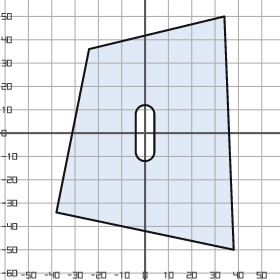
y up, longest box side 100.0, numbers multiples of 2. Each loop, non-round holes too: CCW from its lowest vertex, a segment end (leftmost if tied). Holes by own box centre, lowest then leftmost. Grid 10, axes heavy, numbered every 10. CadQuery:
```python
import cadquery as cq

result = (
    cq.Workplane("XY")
    .moveTo(38.0, -50.0)
    .lineTo(34.0, 50.0)
    .lineTo(-24.0, 36.0)
    .lineTo(-38.0, -34.0)
    .close()
    .moveTo(-4.0, -8.0)
    .threePointArc((0.0, -12.0), (4.0, -8.0))
    .lineTo(4.0, 8.0)
    .threePointArc((0.0, 12.0), (-4.0, 8.0))
    .close()
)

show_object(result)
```